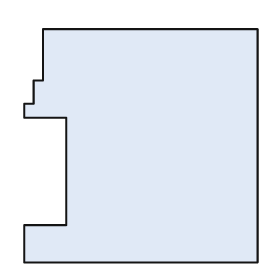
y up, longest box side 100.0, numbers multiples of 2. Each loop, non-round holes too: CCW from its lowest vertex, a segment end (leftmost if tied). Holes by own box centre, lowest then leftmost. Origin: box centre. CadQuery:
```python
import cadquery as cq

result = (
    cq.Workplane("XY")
    .moveTo(-50.0, -50.0)
    .lineTo(50.0, -50.0)
    .lineTo(50.0, 50.0)
    .lineTo(-42.0, 50.0)
    .lineTo(-42.0, 28.0)
    .lineTo(-46.0, 28.0)
    .lineTo(-46.0, 18.0)
    .lineTo(-50.0, 18.0)
    .lineTo(-50.0, 12.0)
    .lineTo(-32.0, 12.0)
    .lineTo(-32.0, -34.0)
    .lineTo(-50.0, -34.0)
    .close()
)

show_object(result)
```